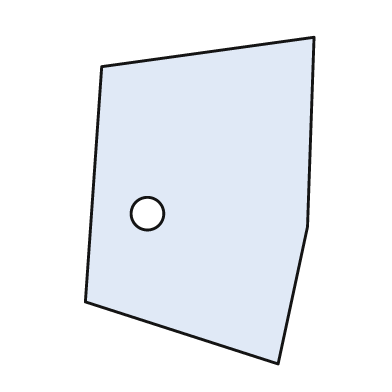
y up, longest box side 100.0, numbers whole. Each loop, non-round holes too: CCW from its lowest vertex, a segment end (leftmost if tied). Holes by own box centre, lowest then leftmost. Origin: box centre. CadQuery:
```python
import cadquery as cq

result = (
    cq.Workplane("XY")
    .moveTo(24.0, -50.0)
    .lineTo(33.0, -8.0)
    .lineTo(35.0, 50.0)
    .lineTo(-30.0, 41.0)
    .lineTo(-35.0, -31.0)
    .close()
    .moveTo(-16.0, -4.0)
    .circle(5.0)
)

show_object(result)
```